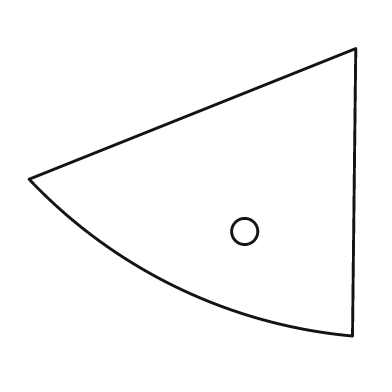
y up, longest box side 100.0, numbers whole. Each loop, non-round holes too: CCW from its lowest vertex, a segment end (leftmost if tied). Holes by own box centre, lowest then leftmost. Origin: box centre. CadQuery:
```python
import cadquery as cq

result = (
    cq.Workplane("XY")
    .moveTo(49.0, -44.0)
    .lineTo(50.0, 44.0)
    .lineTo(-50.0, 4.0)
    .threePointArc((-5.0, -29.0), (49.0, -44.0))
    .close()
    .moveTo(16.0, -12.0)
    .circle(4.0)
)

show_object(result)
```